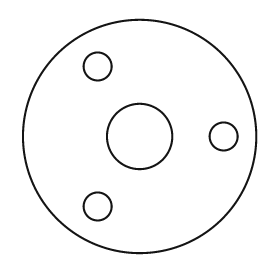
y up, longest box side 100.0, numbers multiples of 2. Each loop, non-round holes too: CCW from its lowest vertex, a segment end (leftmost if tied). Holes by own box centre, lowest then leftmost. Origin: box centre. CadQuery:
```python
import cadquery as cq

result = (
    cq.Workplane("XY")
    .moveTo(0.0, 0.0)
    .circle(50.0)
    .moveTo(-18.0, -30.0)
    .circle(6.0)
    .moveTo(0.0, 0.0)
    .circle(14.0)
    .moveTo(36.0, 0.0)
    .circle(6.0)
    .moveTo(-18.0, 30.0)
    .circle(6.0)
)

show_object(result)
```